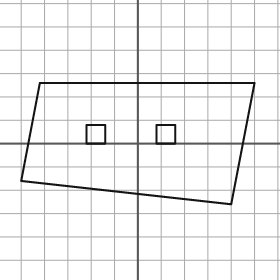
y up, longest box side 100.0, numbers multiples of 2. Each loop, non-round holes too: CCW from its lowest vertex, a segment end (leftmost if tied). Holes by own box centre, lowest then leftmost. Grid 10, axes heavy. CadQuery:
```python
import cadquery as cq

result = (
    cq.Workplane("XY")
    .moveTo(40.0, -26.0)
    .lineTo(50.0, 26.0)
    .lineTo(-42.0, 26.0)
    .lineTo(-50.0, -16.0)
    .close()
    .moveTo(-22.0, 0.0)
    .lineTo(-14.0, 0.0)
    .lineTo(-14.0, 8.0)
    .lineTo(-22.0, 8.0)
    .close()
    .moveTo(8.0, 0.0)
    .lineTo(16.0, 0.0)
    .lineTo(16.0, 8.0)
    .lineTo(8.0, 8.0)
    .close()
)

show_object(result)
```